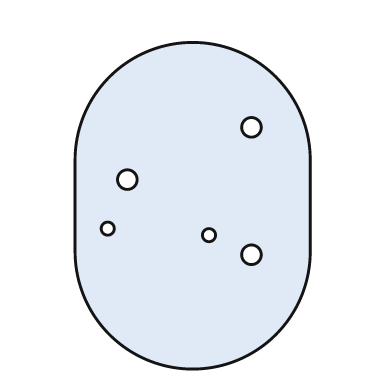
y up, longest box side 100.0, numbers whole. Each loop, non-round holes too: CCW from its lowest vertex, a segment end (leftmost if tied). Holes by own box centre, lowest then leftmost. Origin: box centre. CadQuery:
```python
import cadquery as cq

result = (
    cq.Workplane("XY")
    .moveTo(-36.0, -14.0)
    .threePointArc((0.0, -50.0), (36.0, -14.0))
    .lineTo(36.0, 14.0)
    .threePointArc((0.0, 50.0), (-36.0, 14.0))
    .close()
    .moveTo(18.0, -15.0)
    .circle(3.0)
    .moveTo(5.0, -9.0)
    .circle(2.0)
    .moveTo(-26.0, -7.0)
    .circle(2.0)
    .moveTo(-20.0, 8.0)
    .circle(3.0)
    .moveTo(18.0, 24.0)
    .circle(3.0)
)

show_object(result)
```